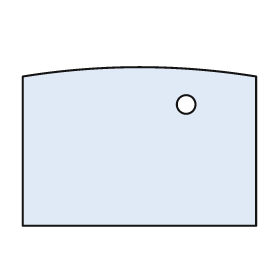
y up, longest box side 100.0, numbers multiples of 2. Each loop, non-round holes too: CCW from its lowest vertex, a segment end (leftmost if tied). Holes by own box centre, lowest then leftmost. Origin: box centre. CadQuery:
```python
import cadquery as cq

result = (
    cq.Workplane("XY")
    .moveTo(-50.0, -34.0)
    .lineTo(50.0, -34.0)
    .lineTo(50.0, 30.0)
    .threePointArc((0.0, 34.0), (-50.0, 30.0))
    .close()
    .moveTo(20.0, 18.0)
    .circle(4.0)
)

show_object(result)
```